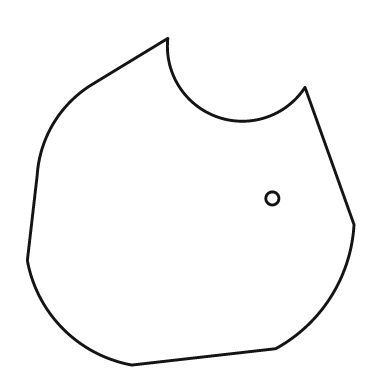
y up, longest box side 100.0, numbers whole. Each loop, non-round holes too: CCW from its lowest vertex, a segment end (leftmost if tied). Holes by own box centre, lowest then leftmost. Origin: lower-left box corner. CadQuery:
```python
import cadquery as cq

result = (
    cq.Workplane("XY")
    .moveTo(32.0, 0.0)
    .lineTo(76.0, 5.0)
    .threePointArc((93.0, 21.0), (100.0, 43.0))
    .lineTo(85.0, 85.0)
    .threePointArc((58.0, 76.0), (43.0, 100.0))
    .lineTo(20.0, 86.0)
    .threePointArc((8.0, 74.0), (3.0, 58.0))
    .lineTo(0.0, 32.0)
    .threePointArc((11.0, 11.0), (32.0, 0.0))
    .close()
    .moveTo(75.0, 51.0)
    .circle(2.0)
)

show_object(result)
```